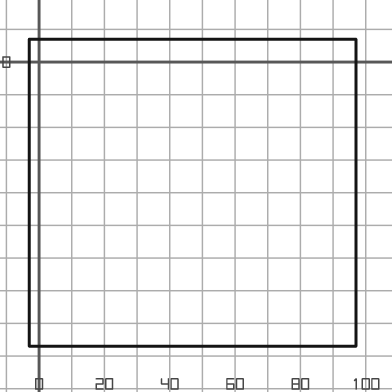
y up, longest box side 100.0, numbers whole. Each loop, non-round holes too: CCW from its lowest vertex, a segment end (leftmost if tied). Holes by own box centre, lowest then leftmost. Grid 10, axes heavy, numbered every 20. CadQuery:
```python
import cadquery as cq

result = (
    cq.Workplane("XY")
    .moveTo(-3.0, -87.0)
    .lineTo(97.0, -87.0)
    .lineTo(97.0, 7.0)
    .lineTo(-3.0, 7.0)
    .close()
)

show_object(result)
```